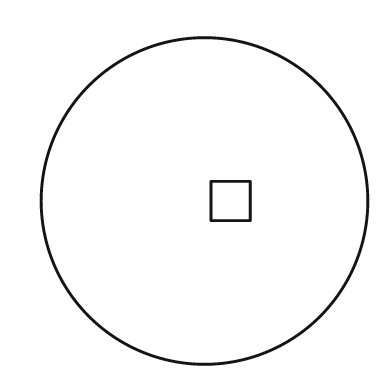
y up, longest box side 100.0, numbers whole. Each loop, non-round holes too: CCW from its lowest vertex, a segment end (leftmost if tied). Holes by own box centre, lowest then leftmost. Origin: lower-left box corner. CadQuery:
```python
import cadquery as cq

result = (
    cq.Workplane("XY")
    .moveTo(50.0, 50.0)
    .circle(50.0)
    .moveTo(52.0, 44.0)
    .lineTo(64.0, 44.0)
    .lineTo(64.0, 56.0)
    .lineTo(52.0, 56.0)
    .close()
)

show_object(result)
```